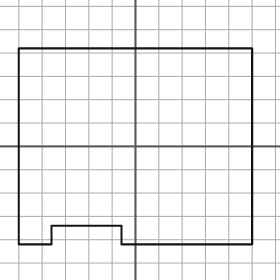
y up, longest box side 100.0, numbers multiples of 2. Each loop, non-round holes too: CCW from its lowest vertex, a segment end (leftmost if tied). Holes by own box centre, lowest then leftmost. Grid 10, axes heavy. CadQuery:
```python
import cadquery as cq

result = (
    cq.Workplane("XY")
    .moveTo(-50.0, -42.0)
    .lineTo(-36.0, -42.0)
    .lineTo(-36.0, -34.0)
    .lineTo(-6.0, -34.0)
    .lineTo(-6.0, -42.0)
    .lineTo(50.0, -42.0)
    .lineTo(50.0, 42.0)
    .lineTo(-50.0, 42.0)
    .close()
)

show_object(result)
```